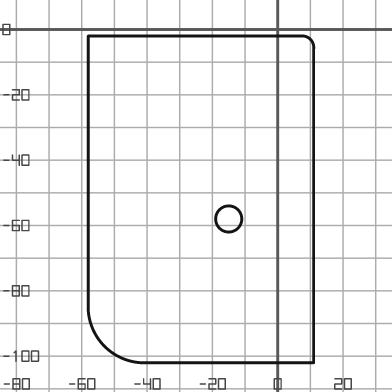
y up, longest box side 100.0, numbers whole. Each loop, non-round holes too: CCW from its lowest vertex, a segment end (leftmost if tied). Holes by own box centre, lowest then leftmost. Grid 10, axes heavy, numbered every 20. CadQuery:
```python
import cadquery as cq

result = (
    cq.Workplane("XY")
    .moveTo(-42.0, -102.0)
    .lineTo(11.0, -102.0)
    .lineTo(11.0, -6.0)
    .threePointArc((10.0, -3.0), (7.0, -2.0))
    .lineTo(-58.0, -2.0)
    .lineTo(-58.0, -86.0)
    .threePointArc((-53.0, -97.0), (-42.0, -102.0))
    .close()
    .moveTo(-15.0, -58.0)
    .circle(4.0)
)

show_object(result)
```